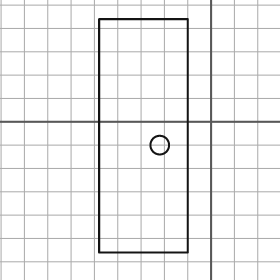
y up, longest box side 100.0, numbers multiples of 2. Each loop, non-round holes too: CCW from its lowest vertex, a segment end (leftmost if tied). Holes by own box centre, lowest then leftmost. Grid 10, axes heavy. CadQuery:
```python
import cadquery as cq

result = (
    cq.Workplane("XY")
    .moveTo(-48.0, -56.0)
    .lineTo(-10.0, -56.0)
    .lineTo(-10.0, 44.0)
    .lineTo(-48.0, 44.0)
    .close()
    .moveTo(-22.0, -10.0)
    .circle(4.0)
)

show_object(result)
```